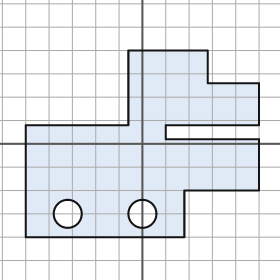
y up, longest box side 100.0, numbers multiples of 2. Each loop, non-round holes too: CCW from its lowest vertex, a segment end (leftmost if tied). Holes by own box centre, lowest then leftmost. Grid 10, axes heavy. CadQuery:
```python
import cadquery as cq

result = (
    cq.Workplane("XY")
    .moveTo(-50.0, -40.0)
    .lineTo(18.0, -40.0)
    .lineTo(18.0, -20.0)
    .lineTo(50.0, -20.0)
    .lineTo(50.0, 2.0)
    .lineTo(10.0, 2.0)
    .lineTo(10.0, 8.0)
    .lineTo(50.0, 8.0)
    .lineTo(50.0, 26.0)
    .lineTo(28.0, 26.0)
    .lineTo(28.0, 40.0)
    .lineTo(-6.0, 40.0)
    .lineTo(-6.0, 8.0)
    .lineTo(-50.0, 8.0)
    .close()
    .moveTo(-32.0, -30.0)
    .circle(6.0)
    .moveTo(0.0, -30.0)
    .circle(6.0)
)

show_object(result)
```